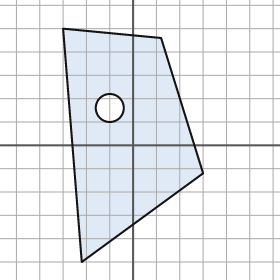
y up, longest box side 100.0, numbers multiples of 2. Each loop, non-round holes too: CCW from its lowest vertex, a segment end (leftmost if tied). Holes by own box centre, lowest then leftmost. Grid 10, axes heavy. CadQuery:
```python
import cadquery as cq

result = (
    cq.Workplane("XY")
    .moveTo(-22.0, -50.0)
    .lineTo(30.0, -12.0)
    .lineTo(12.0, 46.0)
    .lineTo(-30.0, 50.0)
    .close()
    .moveTo(-10.0, 16.0)
    .circle(6.0)
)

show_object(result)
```